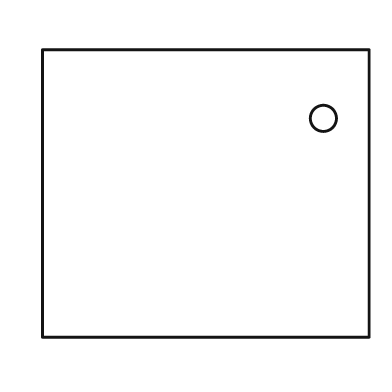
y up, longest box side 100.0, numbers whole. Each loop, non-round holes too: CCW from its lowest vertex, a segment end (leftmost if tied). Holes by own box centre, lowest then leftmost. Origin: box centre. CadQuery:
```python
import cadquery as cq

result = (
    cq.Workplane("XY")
    .moveTo(-50.0, -44.0)
    .lineTo(50.0, -44.0)
    .lineTo(50.0, 44.0)
    .lineTo(-50.0, 44.0)
    .close()
    .moveTo(36.0, 23.0)
    .circle(4.0)
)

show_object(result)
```